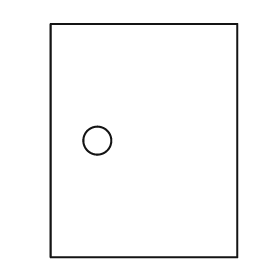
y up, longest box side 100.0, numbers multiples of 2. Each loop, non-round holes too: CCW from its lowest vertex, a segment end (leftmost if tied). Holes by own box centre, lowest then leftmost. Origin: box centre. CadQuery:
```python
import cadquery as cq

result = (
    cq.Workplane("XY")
    .moveTo(-40.0, -50.0)
    .lineTo(40.0, -50.0)
    .lineTo(40.0, 50.0)
    .lineTo(-40.0, 50.0)
    .close()
    .moveTo(-20.0, 0.0)
    .circle(6.0)
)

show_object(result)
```